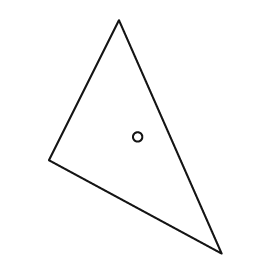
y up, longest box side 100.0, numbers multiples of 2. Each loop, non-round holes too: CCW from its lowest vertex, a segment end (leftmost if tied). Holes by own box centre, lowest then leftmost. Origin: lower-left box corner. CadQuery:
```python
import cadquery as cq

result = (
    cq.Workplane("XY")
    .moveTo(74.0, 0.0)
    .lineTo(30.0, 100.0)
    .lineTo(0.0, 40.0)
    .close()
    .moveTo(38.0, 50.0)
    .circle(2.0)
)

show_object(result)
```